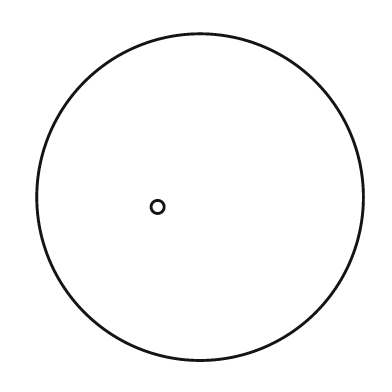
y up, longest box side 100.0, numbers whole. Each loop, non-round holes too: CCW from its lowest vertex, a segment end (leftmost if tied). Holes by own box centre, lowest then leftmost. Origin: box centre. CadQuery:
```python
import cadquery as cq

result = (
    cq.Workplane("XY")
    .moveTo(0.0, 0.0)
    .circle(50.0)
    .moveTo(-13.0, -3.0)
    .circle(2.0)
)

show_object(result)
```